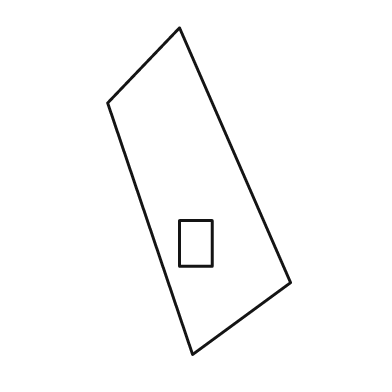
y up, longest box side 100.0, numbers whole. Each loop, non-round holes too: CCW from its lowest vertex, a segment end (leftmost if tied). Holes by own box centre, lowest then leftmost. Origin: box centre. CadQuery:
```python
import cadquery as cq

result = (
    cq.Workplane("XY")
    .moveTo(-2.0, -50.0)
    .lineTo(28.0, -28.0)
    .lineTo(-6.0, 50.0)
    .lineTo(-28.0, 27.0)
    .close()
    .moveTo(-6.0, -23.0)
    .lineTo(4.0, -23.0)
    .lineTo(4.0, -9.0)
    .lineTo(-6.0, -9.0)
    .close()
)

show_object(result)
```